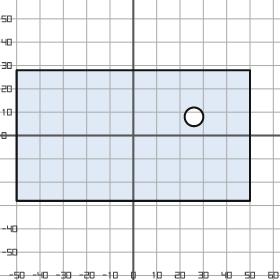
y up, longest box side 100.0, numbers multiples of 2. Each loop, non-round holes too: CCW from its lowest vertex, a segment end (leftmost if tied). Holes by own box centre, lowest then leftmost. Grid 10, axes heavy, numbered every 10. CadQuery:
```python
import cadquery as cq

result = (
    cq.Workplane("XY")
    .moveTo(-50.0, -28.0)
    .lineTo(50.0, -28.0)
    .lineTo(50.0, 28.0)
    .lineTo(-50.0, 28.0)
    .close()
    .moveTo(26.0, 8.0)
    .circle(4.0)
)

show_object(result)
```